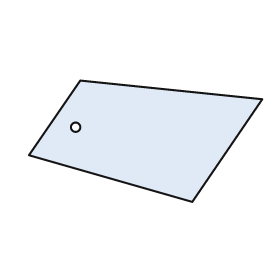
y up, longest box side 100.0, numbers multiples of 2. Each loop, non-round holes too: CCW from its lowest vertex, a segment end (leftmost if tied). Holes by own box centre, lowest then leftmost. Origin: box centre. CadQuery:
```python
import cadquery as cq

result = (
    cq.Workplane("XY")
    .moveTo(20.0, -26.0)
    .lineTo(50.0, 18.0)
    .lineTo(-28.0, 26.0)
    .lineTo(-50.0, -6.0)
    .close()
    .moveTo(-30.0, 6.0)
    .circle(2.0)
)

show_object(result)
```